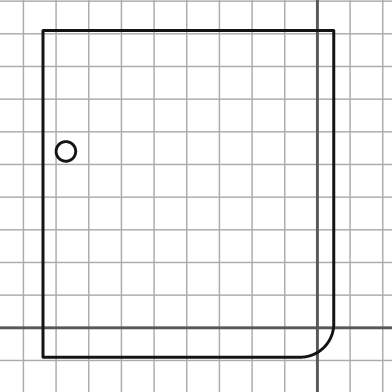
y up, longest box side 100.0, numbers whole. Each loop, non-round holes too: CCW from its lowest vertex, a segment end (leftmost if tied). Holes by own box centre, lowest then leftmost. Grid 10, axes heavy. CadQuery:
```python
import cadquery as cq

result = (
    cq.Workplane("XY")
    .moveTo(-84.0, -9.0)
    .lineTo(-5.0, -9.0)
    .threePointArc((2.0, -6.0), (5.0, 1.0))
    .lineTo(5.0, 91.0)
    .lineTo(-84.0, 91.0)
    .close()
    .moveTo(-77.0, 54.0)
    .circle(3.0)
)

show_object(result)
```